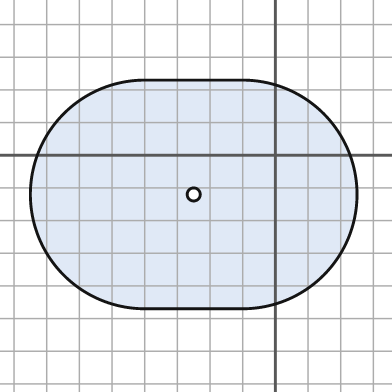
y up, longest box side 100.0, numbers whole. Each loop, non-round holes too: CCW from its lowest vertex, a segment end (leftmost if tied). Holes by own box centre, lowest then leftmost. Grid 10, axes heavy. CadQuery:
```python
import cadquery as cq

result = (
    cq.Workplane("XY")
    .moveTo(-40.0, -47.0)
    .lineTo(-10.0, -47.0)
    .threePointArc((25.0, -12.0), (-10.0, 23.0))
    .lineTo(-40.0, 23.0)
    .threePointArc((-75.0, -12.0), (-40.0, -47.0))
    .close()
    .moveTo(-25.0, -12.0)
    .circle(2.0)
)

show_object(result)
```